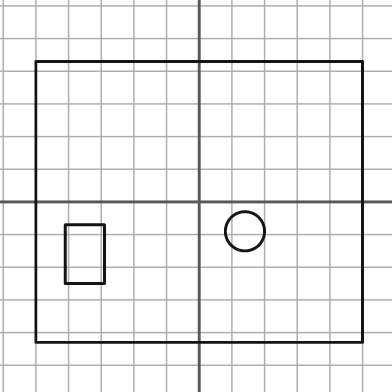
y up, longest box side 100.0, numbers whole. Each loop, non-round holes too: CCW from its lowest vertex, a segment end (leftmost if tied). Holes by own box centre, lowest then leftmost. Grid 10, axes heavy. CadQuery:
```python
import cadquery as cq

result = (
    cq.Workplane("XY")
    .moveTo(-50.0, -43.0)
    .lineTo(50.0, -43.0)
    .lineTo(50.0, 43.0)
    .lineTo(-50.0, 43.0)
    .close()
    .moveTo(-41.0, -25.0)
    .lineTo(-29.0, -25.0)
    .lineTo(-29.0, -7.0)
    .lineTo(-41.0, -7.0)
    .close()
    .moveTo(14.0, -9.0)
    .circle(6.0)
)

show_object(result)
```